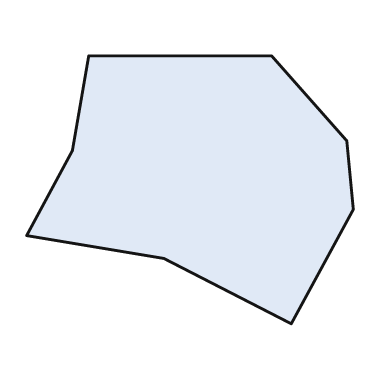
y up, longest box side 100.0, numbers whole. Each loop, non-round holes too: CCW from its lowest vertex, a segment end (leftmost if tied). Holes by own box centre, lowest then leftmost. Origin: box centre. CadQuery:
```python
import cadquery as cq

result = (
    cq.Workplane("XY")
    .moveTo(31.0, -41.0)
    .lineTo(50.0, -6.0)
    .lineTo(48.0, 15.0)
    .lineTo(25.0, 41.0)
    .lineTo(-31.0, 41.0)
    .lineTo(-36.0, 12.0)
    .lineTo(-50.0, -14.0)
    .lineTo(-8.0, -21.0)
    .close()
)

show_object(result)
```